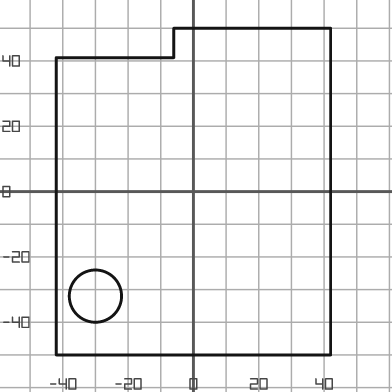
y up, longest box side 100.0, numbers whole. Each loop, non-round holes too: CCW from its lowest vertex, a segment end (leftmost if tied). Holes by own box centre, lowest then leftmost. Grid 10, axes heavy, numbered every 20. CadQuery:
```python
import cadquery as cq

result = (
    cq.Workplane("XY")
    .moveTo(-42.0, -50.0)
    .lineTo(42.0, -50.0)
    .lineTo(42.0, 50.0)
    .lineTo(-6.0, 50.0)
    .lineTo(-6.0, 41.0)
    .lineTo(-42.0, 41.0)
    .close()
    .moveTo(-30.0, -32.0)
    .circle(8.0)
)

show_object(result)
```